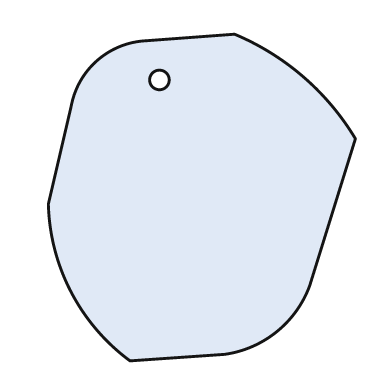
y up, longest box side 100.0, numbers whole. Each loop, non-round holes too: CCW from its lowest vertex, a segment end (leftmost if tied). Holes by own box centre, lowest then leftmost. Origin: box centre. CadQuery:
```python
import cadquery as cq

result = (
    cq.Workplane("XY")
    .moveTo(-22.0, -50.0)
    .lineTo(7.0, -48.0)
    .threePointArc((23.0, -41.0), (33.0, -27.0))
    .lineTo(47.0, 18.0)
    .threePointArc((31.0, 37.0), (10.0, 50.0))
    .lineTo(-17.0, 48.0)
    .threePointArc((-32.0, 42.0), (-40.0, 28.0))
    .lineTo(-47.0, -2.0)
    .threePointArc((-40.0, -29.0), (-22.0, -50.0))
    .close()
    .moveTo(-13.0, 36.0)
    .circle(3.0)
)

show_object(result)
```